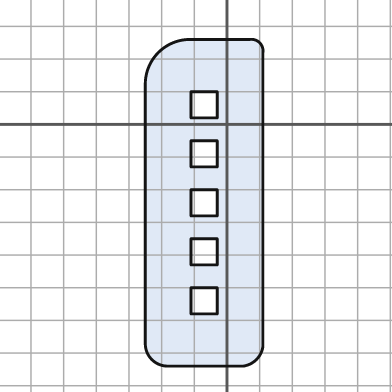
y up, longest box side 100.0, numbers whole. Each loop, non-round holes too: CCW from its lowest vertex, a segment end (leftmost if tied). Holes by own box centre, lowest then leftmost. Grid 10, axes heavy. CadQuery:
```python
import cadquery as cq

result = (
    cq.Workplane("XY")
    .moveTo(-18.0, -74.0)
    .lineTo(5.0, -74.0)
    .threePointArc((9.0, -72.0), (11.0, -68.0))
    .lineTo(11.0, 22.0)
    .threePointArc((10.0, 25.0), (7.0, 26.0))
    .lineTo(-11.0, 26.0)
    .threePointArc((-21.0, 22.0), (-25.0, 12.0))
    .lineTo(-25.0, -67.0)
    .threePointArc((-23.0, -72.0), (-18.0, -74.0))
    .close()
    .moveTo(-11.0, -58.0)
    .lineTo(-3.0, -58.0)
    .lineTo(-3.0, -50.0)
    .lineTo(-11.0, -50.0)
    .close()
    .moveTo(-11.0, -43.0)
    .lineTo(-3.0, -43.0)
    .lineTo(-3.0, -35.0)
    .lineTo(-11.0, -35.0)
    .close()
    .moveTo(-11.0, -28.0)
    .lineTo(-3.0, -28.0)
    .lineTo(-3.0, -20.0)
    .lineTo(-11.0, -20.0)
    .close()
    .moveTo(-11.0, -13.0)
    .lineTo(-3.0, -13.0)
    .lineTo(-3.0, -5.0)
    .lineTo(-11.0, -5.0)
    .close()
    .moveTo(-11.0, 2.0)
    .lineTo(-3.0, 2.0)
    .lineTo(-3.0, 10.0)
    .lineTo(-11.0, 10.0)
    .close()
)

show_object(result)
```